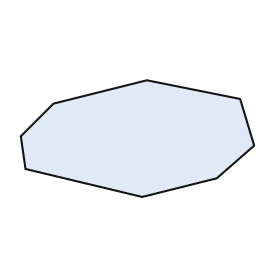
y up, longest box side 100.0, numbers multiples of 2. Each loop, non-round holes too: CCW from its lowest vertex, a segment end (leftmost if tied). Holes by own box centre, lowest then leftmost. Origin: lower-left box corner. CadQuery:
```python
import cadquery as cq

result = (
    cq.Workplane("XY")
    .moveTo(52.0, 0.0)
    .lineTo(84.0, 8.0)
    .lineTo(100.0, 22.0)
    .lineTo(94.0, 42.0)
    .lineTo(54.0, 50.0)
    .lineTo(14.0, 40.0)
    .lineTo(0.0, 26.0)
    .lineTo(2.0, 12.0)
    .close()
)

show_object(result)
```